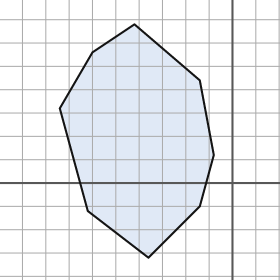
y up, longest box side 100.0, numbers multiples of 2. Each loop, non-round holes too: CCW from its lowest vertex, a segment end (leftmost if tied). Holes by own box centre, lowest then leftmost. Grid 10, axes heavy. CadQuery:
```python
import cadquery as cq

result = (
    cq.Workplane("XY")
    .moveTo(-36.0, -32.0)
    .lineTo(-14.0, -10.0)
    .lineTo(-8.0, 12.0)
    .lineTo(-14.0, 44.0)
    .lineTo(-42.0, 68.0)
    .lineTo(-60.0, 56.0)
    .lineTo(-74.0, 32.0)
    .lineTo(-62.0, -12.0)
    .close()
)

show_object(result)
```